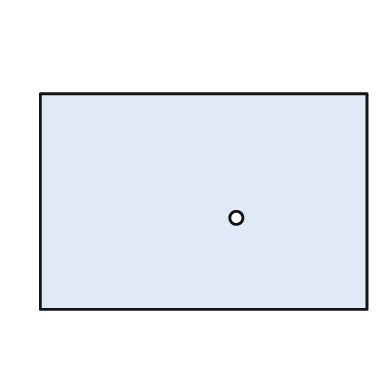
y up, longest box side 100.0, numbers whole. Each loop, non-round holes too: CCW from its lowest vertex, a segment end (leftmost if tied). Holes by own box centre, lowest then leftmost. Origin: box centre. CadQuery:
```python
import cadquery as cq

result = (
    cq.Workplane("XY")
    .moveTo(-50.0, -33.0)
    .lineTo(50.0, -33.0)
    .lineTo(50.0, 33.0)
    .lineTo(-50.0, 33.0)
    .close()
    .moveTo(10.0, -5.0)
    .circle(2.0)
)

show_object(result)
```